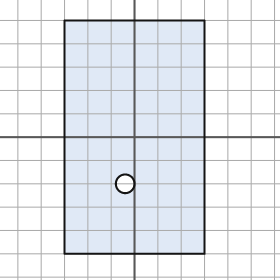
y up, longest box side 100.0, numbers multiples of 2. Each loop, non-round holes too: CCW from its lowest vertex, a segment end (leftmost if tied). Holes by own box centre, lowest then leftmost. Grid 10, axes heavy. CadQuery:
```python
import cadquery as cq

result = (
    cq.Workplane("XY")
    .moveTo(-30.0, -50.0)
    .lineTo(30.0, -50.0)
    .lineTo(30.0, 50.0)
    .lineTo(-30.0, 50.0)
    .close()
    .moveTo(-4.0, -20.0)
    .circle(4.0)
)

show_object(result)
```